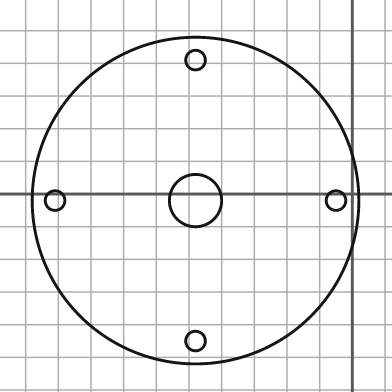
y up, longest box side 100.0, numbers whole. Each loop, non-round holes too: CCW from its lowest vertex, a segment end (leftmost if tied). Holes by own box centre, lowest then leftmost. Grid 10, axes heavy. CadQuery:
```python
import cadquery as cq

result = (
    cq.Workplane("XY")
    .moveTo(-48.0, -2.0)
    .circle(50.0)
    .moveTo(-48.0, -45.0)
    .circle(3.0)
    .moveTo(-91.0, -2.0)
    .circle(3.0)
    .moveTo(-48.0, -2.0)
    .circle(8.0)
    .moveTo(-5.0, -2.0)
    .circle(3.0)
    .moveTo(-48.0, 41.0)
    .circle(3.0)
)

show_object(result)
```